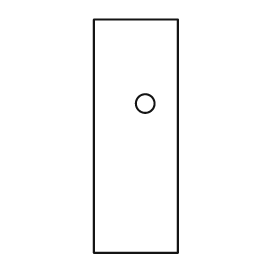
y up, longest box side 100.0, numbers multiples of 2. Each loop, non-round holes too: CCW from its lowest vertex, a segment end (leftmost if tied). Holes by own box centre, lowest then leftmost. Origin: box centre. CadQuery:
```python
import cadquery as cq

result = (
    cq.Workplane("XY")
    .moveTo(-18.0, -50.0)
    .lineTo(18.0, -50.0)
    .lineTo(18.0, 50.0)
    .lineTo(-18.0, 50.0)
    .close()
    .moveTo(4.0, 14.0)
    .circle(4.0)
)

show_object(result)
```